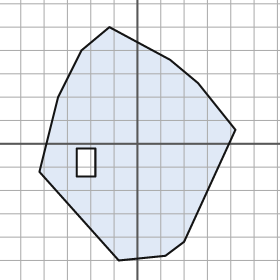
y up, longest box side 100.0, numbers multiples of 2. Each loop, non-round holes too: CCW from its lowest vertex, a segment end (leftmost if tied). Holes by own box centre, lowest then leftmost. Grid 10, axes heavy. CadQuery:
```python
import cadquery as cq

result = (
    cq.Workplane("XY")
    .moveTo(-8.0, -50.0)
    .lineTo(12.0, -48.0)
    .lineTo(20.0, -42.0)
    .lineTo(42.0, 6.0)
    .lineTo(26.0, 26.0)
    .lineTo(14.0, 36.0)
    .lineTo(-12.0, 50.0)
    .lineTo(-24.0, 40.0)
    .lineTo(-34.0, 20.0)
    .lineTo(-42.0, -12.0)
    .close()
    .moveTo(-26.0, -14.0)
    .lineTo(-18.0, -14.0)
    .lineTo(-18.0, -2.0)
    .lineTo(-26.0, -2.0)
    .close()
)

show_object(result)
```